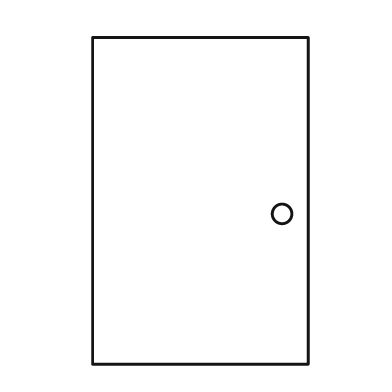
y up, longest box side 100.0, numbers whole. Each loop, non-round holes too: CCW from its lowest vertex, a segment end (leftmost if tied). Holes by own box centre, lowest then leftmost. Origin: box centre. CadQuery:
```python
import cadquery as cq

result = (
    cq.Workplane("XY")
    .moveTo(-33.0, -50.0)
    .lineTo(33.0, -50.0)
    .lineTo(33.0, 50.0)
    .lineTo(-33.0, 50.0)
    .close()
    .moveTo(25.0, -4.0)
    .circle(3.0)
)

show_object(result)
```